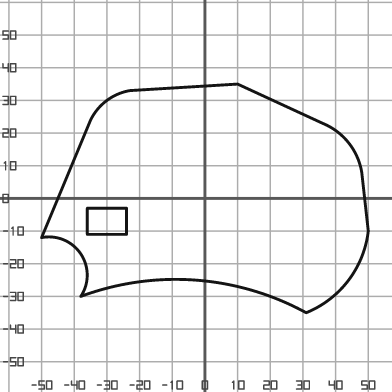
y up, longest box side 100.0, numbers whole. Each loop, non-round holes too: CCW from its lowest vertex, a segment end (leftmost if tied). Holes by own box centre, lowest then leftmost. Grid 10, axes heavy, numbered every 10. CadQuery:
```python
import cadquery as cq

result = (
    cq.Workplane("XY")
    .moveTo(31.0, -35.0)
    .threePointArc((44.0, -25.0), (50.0, -10.0))
    .lineTo(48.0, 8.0)
    .threePointArc((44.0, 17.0), (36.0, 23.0))
    .lineTo(10.0, 35.0)
    .lineTo(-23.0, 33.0)
    .threePointArc((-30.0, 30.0), (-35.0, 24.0))
    .lineTo(-50.0, -12.0)
    .threePointArc((-38.0, -17.0), (-38.0, -30.0))
    .threePointArc((-3.0, -25.0), (31.0, -35.0))
    .close()
    .moveTo(-36.0, -11.0)
    .lineTo(-24.0, -11.0)
    .lineTo(-24.0, -3.0)
    .lineTo(-36.0, -3.0)
    .close()
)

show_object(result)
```